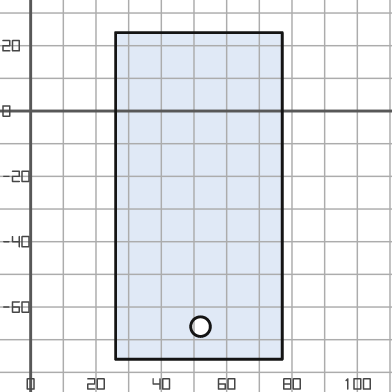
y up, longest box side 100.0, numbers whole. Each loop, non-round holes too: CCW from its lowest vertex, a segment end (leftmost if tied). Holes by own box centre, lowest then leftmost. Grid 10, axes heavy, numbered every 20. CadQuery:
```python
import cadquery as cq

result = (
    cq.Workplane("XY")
    .moveTo(26.0, -76.0)
    .lineTo(77.0, -76.0)
    .lineTo(77.0, 24.0)
    .lineTo(26.0, 24.0)
    .close()
    .moveTo(52.0, -66.0)
    .circle(3.0)
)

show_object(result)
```